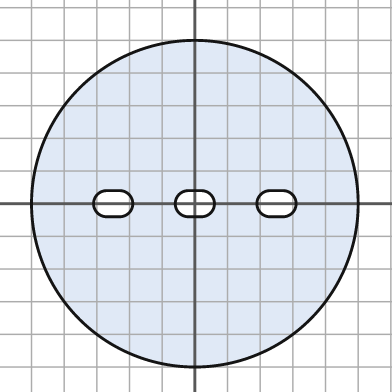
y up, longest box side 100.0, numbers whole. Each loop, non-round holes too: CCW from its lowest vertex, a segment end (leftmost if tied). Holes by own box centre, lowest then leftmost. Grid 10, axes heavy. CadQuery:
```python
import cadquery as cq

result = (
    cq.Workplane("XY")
    .moveTo(0.0, 0.0)
    .circle(50.0)
    .moveTo(-27.0, -4.0)
    .lineTo(-23.0, -4.0)
    .threePointArc((-19.0, 0.0), (-23.0, 4.0))
    .lineTo(-27.0, 4.0)
    .threePointArc((-31.0, 0.0), (-27.0, -4.0))
    .close()
    .moveTo(-2.0, -4.0)
    .lineTo(2.0, -4.0)
    .threePointArc((6.0, 0.0), (2.0, 4.0))
    .lineTo(-2.0, 4.0)
    .threePointArc((-6.0, 0.0), (-2.0, -4.0))
    .close()
    .moveTo(23.0, -4.0)
    .lineTo(27.0, -4.0)
    .threePointArc((31.0, 0.0), (27.0, 4.0))
    .lineTo(23.0, 4.0)
    .threePointArc((19.0, 0.0), (23.0, -4.0))
    .close()
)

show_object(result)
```